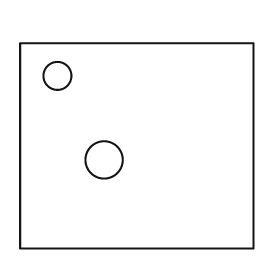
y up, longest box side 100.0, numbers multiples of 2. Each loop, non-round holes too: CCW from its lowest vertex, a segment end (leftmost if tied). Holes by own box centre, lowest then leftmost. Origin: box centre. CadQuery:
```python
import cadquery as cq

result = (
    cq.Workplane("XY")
    .moveTo(-50.0, -44.0)
    .lineTo(50.0, -44.0)
    .lineTo(50.0, 44.0)
    .lineTo(-50.0, 44.0)
    .close()
    .moveTo(-14.0, -6.0)
    .circle(8.0)
    .moveTo(-34.0, 30.0)
    .circle(6.0)
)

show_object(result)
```